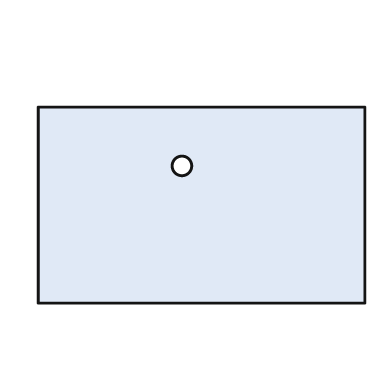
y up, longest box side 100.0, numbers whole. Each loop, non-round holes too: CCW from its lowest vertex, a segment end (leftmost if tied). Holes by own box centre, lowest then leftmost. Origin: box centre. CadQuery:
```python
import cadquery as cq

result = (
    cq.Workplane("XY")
    .moveTo(-50.0, -30.0)
    .lineTo(50.0, -30.0)
    .lineTo(50.0, 30.0)
    .lineTo(-50.0, 30.0)
    .close()
    .moveTo(-6.0, 12.0)
    .circle(3.0)
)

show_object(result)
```